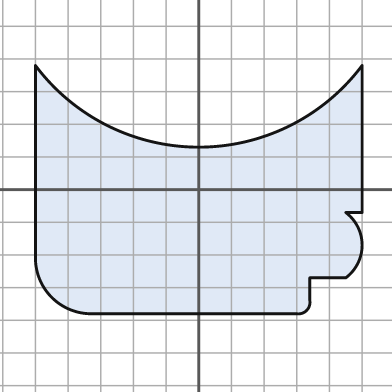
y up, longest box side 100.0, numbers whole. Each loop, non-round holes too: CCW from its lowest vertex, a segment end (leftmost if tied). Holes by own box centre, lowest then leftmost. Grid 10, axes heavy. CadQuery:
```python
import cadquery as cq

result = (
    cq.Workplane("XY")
    .moveTo(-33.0, -38.0)
    .lineTo(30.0, -38.0)
    .threePointArc((33.0, -37.0), (34.0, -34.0))
    .lineTo(34.0, -27.0)
    .lineTo(45.0, -27.0)
    .threePointArc((50.0, -17.0), (45.0, -7.0))
    .lineTo(50.0, -7.0)
    .lineTo(50.0, 38.0)
    .threePointArc((0.0, 13.0), (-50.0, 38.0))
    .lineTo(-50.0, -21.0)
    .threePointArc((-45.0, -33.0), (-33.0, -38.0))
    .close()
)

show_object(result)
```